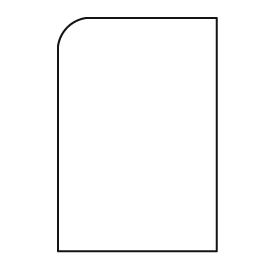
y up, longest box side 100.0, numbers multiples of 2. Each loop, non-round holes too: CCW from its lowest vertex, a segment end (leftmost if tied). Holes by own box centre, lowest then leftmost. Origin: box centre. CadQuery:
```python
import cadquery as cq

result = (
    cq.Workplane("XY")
    .moveTo(-34.0, -50.0)
    .lineTo(34.0, -50.0)
    .lineTo(34.0, 50.0)
    .lineTo(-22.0, 50.0)
    .threePointArc((-30.0, 46.0), (-34.0, 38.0))
    .close()
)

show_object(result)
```